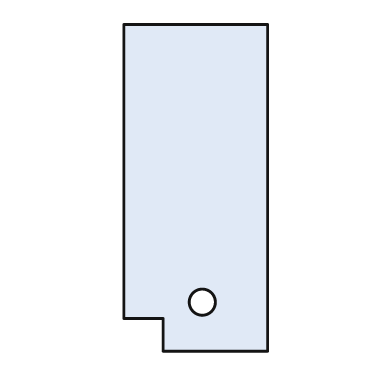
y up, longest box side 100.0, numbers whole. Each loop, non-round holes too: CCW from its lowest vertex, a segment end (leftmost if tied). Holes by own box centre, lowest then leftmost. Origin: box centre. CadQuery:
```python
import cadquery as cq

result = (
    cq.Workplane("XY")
    .moveTo(-10.0, -50.0)
    .lineTo(22.0, -50.0)
    .lineTo(22.0, 50.0)
    .lineTo(-22.0, 50.0)
    .lineTo(-22.0, -40.0)
    .lineTo(-10.0, -40.0)
    .close()
    .moveTo(2.0, -35.0)
    .circle(4.0)
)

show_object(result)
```